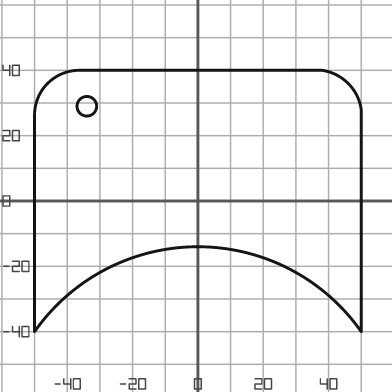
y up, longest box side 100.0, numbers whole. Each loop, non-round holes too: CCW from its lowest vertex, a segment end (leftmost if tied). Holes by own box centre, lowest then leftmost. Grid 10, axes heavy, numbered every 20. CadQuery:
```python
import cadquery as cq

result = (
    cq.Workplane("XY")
    .moveTo(-50.0, -40.0)
    .threePointArc((0.0, -14.0), (50.0, -40.0))
    .lineTo(50.0, 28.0)
    .threePointArc((46.0, 36.0), (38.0, 40.0))
    .lineTo(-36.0, 40.0)
    .threePointArc((-46.0, 36.0), (-50.0, 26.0))
    .close()
    .moveTo(-34.0, 29.0)
    .circle(3.0)
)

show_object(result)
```